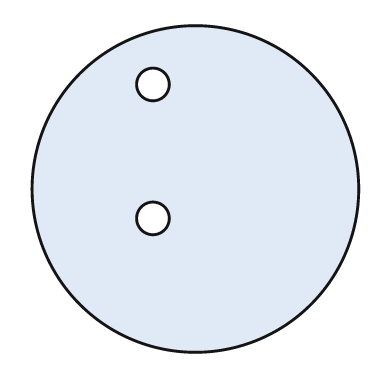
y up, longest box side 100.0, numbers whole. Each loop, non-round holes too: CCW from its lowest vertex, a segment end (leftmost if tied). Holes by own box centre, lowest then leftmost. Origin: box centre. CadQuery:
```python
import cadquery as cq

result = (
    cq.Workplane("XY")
    .moveTo(0.0, 0.0)
    .circle(50.0)
    .moveTo(-13.0, -9.0)
    .circle(5.0)
    .moveTo(-13.0, 32.0)
    .circle(5.0)
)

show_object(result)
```